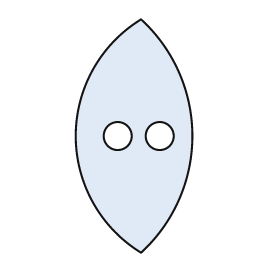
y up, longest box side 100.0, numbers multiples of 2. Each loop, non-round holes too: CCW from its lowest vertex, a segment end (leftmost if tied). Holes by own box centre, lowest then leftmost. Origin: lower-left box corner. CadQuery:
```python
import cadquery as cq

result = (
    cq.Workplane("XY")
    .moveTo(28.0, 0.0)
    .threePointArc((50.0, 50.0), (28.0, 100.0))
    .threePointArc((0.0, 50.0), (28.0, 0.0))
    .close()
    .moveTo(18.0, 50.0)
    .circle(6.0)
    .moveTo(36.0, 50.0)
    .circle(6.0)
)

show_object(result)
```